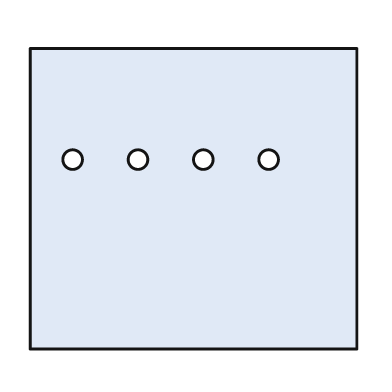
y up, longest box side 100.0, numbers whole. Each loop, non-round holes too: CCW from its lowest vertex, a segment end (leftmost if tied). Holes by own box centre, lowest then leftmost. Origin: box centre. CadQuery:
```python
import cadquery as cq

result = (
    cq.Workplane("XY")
    .moveTo(-50.0, -46.0)
    .lineTo(50.0, -46.0)
    .lineTo(50.0, 46.0)
    .lineTo(-50.0, 46.0)
    .close()
    .moveTo(-37.0, 12.0)
    .circle(3.0)
    .moveTo(-17.0, 12.0)
    .circle(3.0)
    .moveTo(3.0, 12.0)
    .circle(3.0)
    .moveTo(23.0, 12.0)
    .circle(3.0)
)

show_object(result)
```